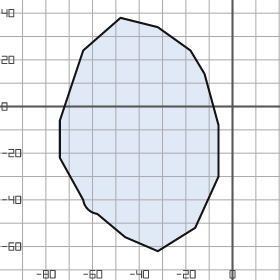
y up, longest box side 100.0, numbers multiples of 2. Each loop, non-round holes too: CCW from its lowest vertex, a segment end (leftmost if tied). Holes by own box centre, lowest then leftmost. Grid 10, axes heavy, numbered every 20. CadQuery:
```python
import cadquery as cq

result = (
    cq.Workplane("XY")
    .moveTo(-32.0, -62.0)
    .lineTo(-16.0, -52.0)
    .lineTo(-6.0, -30.0)
    .lineTo(-6.0, -8.0)
    .lineTo(-12.0, 14.0)
    .lineTo(-18.0, 24.0)
    .lineTo(-32.0, 34.0)
    .lineTo(-48.0, 38.0)
    .lineTo(-64.0, 24.0)
    .lineTo(-74.0, -6.0)
    .lineTo(-74.0, -22.0)
    .lineTo(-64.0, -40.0)
    .threePointArc((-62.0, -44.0), (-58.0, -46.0))
    .lineTo(-46.0, -56.0)
    .close()
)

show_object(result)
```